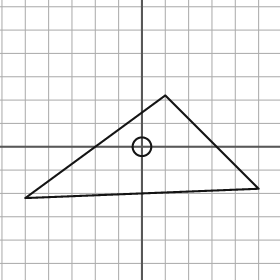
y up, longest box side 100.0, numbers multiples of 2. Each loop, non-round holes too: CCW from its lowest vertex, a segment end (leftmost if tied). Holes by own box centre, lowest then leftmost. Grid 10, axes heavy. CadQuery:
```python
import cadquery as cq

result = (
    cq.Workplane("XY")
    .moveTo(-50.0, -22.0)
    .lineTo(50.0, -18.0)
    .lineTo(10.0, 22.0)
    .close()
    .moveTo(0.0, 0.0)
    .circle(4.0)
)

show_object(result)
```